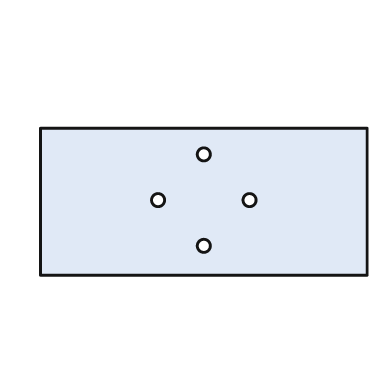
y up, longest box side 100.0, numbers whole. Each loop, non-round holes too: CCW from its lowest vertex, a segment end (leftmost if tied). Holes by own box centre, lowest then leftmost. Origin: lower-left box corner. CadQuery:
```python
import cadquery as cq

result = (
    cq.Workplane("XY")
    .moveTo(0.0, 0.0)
    .lineTo(100.0, 0.0)
    .lineTo(100.0, 45.0)
    .lineTo(0.0, 45.0)
    .close()
    .moveTo(50.0, 9.0)
    .circle(2.0)
    .moveTo(36.0, 23.0)
    .circle(2.0)
    .moveTo(64.0, 23.0)
    .circle(2.0)
    .moveTo(50.0, 37.0)
    .circle(2.0)
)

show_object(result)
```